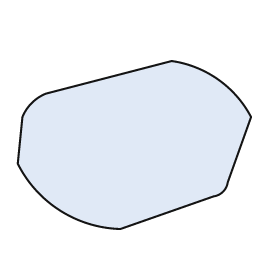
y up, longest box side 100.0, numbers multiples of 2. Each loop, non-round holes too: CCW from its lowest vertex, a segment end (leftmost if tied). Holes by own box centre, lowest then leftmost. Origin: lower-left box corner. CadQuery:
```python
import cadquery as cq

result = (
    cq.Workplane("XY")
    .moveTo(44.0, 0.0)
    .lineTo(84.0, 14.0)
    .threePointArc((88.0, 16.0), (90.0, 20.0))
    .lineTo(100.0, 48.0)
    .threePointArc((86.0, 64.0), (66.0, 72.0))
    .lineTo(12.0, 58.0)
    .threePointArc((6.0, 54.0), (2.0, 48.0))
    .lineTo(0.0, 28.0)
    .threePointArc((18.0, 8.0), (44.0, 0.0))
    .close()
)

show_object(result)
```